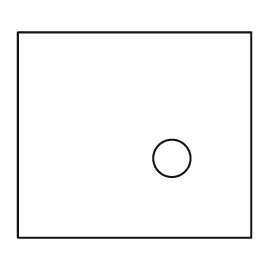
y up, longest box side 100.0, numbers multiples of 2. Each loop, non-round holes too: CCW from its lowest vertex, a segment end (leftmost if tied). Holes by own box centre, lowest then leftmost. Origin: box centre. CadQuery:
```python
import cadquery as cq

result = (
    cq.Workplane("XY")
    .moveTo(-50.0, -44.0)
    .lineTo(50.0, -44.0)
    .lineTo(50.0, 44.0)
    .lineTo(-50.0, 44.0)
    .close()
    .moveTo(16.0, -10.0)
    .circle(8.0)
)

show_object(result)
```